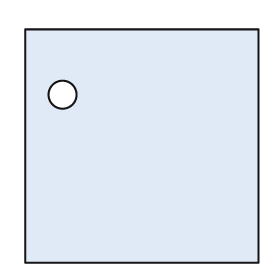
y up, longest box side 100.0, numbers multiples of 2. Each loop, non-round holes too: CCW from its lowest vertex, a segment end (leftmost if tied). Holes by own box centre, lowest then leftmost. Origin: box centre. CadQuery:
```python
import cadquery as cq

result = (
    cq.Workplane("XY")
    .moveTo(-50.0, -50.0)
    .lineTo(50.0, -50.0)
    .lineTo(50.0, 50.0)
    .lineTo(-50.0, 50.0)
    .close()
    .moveTo(-34.0, 22.0)
    .circle(6.0)
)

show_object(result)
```